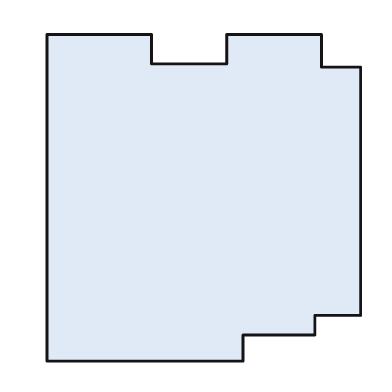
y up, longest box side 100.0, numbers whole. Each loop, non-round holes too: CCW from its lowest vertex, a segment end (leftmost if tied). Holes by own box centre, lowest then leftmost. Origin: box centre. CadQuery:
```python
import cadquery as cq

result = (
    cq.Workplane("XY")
    .moveTo(-48.0, -50.0)
    .lineTo(12.0, -50.0)
    .lineTo(12.0, -42.0)
    .lineTo(34.0, -42.0)
    .lineTo(34.0, -36.0)
    .lineTo(48.0, -36.0)
    .lineTo(48.0, 40.0)
    .lineTo(36.0, 40.0)
    .lineTo(36.0, 50.0)
    .lineTo(7.0, 50.0)
    .lineTo(7.0, 41.0)
    .lineTo(-16.0, 41.0)
    .lineTo(-16.0, 50.0)
    .lineTo(-48.0, 50.0)
    .close()
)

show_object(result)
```